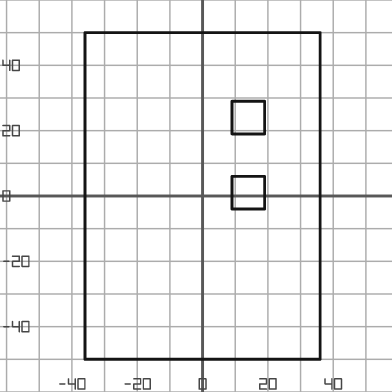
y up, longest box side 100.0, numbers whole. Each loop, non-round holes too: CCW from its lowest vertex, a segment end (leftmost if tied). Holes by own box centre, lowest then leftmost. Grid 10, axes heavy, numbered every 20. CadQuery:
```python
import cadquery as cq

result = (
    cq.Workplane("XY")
    .moveTo(-36.0, -50.0)
    .lineTo(36.0, -50.0)
    .lineTo(36.0, 50.0)
    .lineTo(-36.0, 50.0)
    .close()
    .moveTo(9.0, -4.0)
    .lineTo(19.0, -4.0)
    .lineTo(19.0, 6.0)
    .lineTo(9.0, 6.0)
    .close()
    .moveTo(9.0, 19.0)
    .lineTo(19.0, 19.0)
    .lineTo(19.0, 29.0)
    .lineTo(9.0, 29.0)
    .close()
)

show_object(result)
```